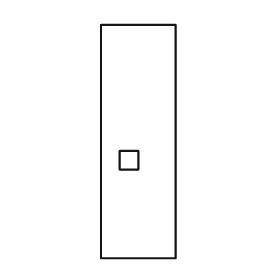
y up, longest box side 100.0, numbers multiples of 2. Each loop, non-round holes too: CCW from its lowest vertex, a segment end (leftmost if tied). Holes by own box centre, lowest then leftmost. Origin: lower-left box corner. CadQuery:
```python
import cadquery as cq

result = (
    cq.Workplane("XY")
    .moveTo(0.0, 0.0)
    .lineTo(32.0, 0.0)
    .lineTo(32.0, 100.0)
    .lineTo(0.0, 100.0)
    .close()
    .moveTo(8.0, 38.0)
    .lineTo(16.0, 38.0)
    .lineTo(16.0, 46.0)
    .lineTo(8.0, 46.0)
    .close()
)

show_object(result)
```